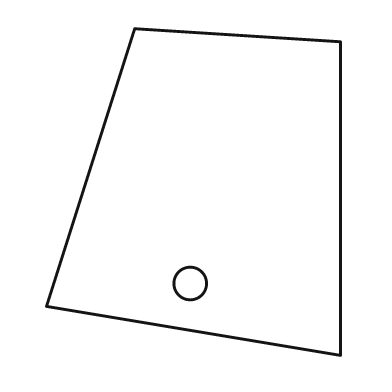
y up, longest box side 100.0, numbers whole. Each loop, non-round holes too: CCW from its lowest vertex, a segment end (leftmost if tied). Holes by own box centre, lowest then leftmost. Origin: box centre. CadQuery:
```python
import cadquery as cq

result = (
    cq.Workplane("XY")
    .moveTo(45.0, -50.0)
    .lineTo(45.0, 46.0)
    .lineTo(-18.0, 50.0)
    .lineTo(-45.0, -35.0)
    .close()
    .moveTo(-1.0, -28.0)
    .circle(5.0)
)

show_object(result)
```